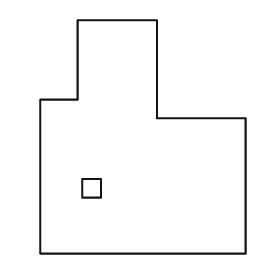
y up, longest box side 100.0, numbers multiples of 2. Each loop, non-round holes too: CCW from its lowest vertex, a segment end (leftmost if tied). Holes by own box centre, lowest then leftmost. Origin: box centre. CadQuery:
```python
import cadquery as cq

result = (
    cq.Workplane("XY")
    .moveTo(-44.0, -50.0)
    .lineTo(44.0, -50.0)
    .lineTo(44.0, 8.0)
    .lineTo(6.0, 8.0)
    .lineTo(6.0, 50.0)
    .lineTo(-28.0, 50.0)
    .lineTo(-28.0, 16.0)
    .lineTo(-44.0, 16.0)
    .close()
    .moveTo(-26.0, -26.0)
    .lineTo(-18.0, -26.0)
    .lineTo(-18.0, -18.0)
    .lineTo(-26.0, -18.0)
    .close()
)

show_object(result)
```